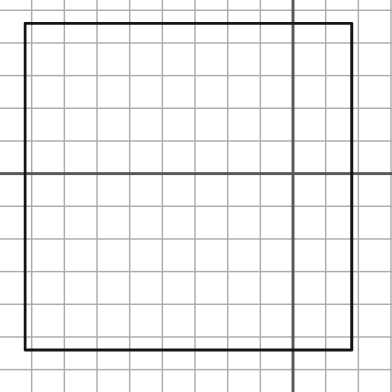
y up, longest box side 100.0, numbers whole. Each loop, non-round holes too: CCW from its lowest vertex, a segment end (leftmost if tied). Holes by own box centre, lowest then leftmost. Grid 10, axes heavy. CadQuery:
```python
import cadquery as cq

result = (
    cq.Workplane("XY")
    .moveTo(-82.0, -54.0)
    .lineTo(18.0, -54.0)
    .lineTo(18.0, 46.0)
    .lineTo(-82.0, 46.0)
    .close()
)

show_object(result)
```